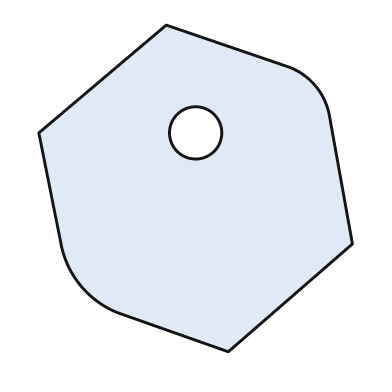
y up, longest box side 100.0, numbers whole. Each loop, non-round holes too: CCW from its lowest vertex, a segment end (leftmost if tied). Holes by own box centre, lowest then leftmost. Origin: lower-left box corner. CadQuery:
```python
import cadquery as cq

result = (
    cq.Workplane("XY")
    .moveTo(58.0, 0.0)
    .lineTo(96.0, 33.0)
    .lineTo(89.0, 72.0)
    .threePointArc((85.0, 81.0), (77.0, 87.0))
    .lineTo(39.0, 100.0)
    .lineTo(0.0, 67.0)
    .lineTo(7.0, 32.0)
    .threePointArc((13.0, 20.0), (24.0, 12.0))
    .close()
    .moveTo(48.0, 67.0)
    .circle(8.0)
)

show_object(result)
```